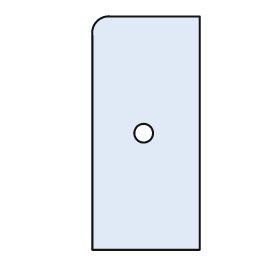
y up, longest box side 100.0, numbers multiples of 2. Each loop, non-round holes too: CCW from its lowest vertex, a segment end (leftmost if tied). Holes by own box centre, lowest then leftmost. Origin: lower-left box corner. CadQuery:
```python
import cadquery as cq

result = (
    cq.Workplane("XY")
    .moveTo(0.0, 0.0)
    .lineTo(46.0, 0.0)
    .lineTo(46.0, 100.0)
    .lineTo(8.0, 100.0)
    .threePointArc((2.0, 98.0), (0.0, 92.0))
    .close()
    .moveTo(22.0, 50.0)
    .circle(4.0)
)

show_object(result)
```